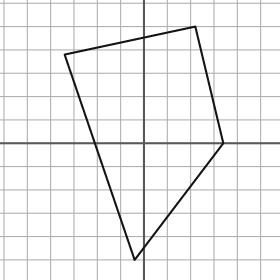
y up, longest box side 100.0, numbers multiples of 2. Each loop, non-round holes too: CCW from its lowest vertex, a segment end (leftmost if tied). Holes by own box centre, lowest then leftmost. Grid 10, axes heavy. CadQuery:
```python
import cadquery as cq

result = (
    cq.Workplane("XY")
    .moveTo(-4.0, -50.0)
    .lineTo(34.0, 0.0)
    .lineTo(22.0, 50.0)
    .lineTo(-34.0, 38.0)
    .close()
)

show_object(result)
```